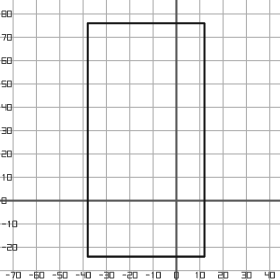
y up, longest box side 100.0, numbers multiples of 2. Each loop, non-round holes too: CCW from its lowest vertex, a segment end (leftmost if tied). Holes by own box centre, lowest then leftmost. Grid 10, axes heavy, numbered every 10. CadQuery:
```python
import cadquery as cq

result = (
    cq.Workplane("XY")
    .moveTo(-38.0, -24.0)
    .lineTo(12.0, -24.0)
    .lineTo(12.0, 76.0)
    .lineTo(-38.0, 76.0)
    .close()
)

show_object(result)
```